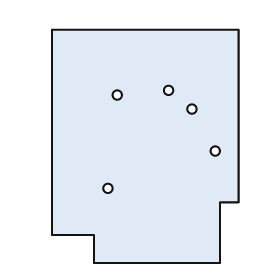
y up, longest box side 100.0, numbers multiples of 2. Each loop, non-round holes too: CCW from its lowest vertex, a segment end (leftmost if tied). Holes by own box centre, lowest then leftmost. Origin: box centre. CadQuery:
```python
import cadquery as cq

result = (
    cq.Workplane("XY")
    .moveTo(-22.0, -50.0)
    .lineTo(32.0, -50.0)
    .lineTo(32.0, -24.0)
    .lineTo(40.0, -24.0)
    .lineTo(40.0, 50.0)
    .lineTo(-40.0, 50.0)
    .lineTo(-40.0, -38.0)
    .lineTo(-22.0, -38.0)
    .close()
    .moveTo(-16.0, -18.0)
    .circle(2.0)
    .moveTo(30.0, -2.0)
    .circle(2.0)
    .moveTo(20.0, 16.0)
    .circle(2.0)
    .moveTo(-12.0, 22.0)
    .circle(2.0)
    .moveTo(10.0, 24.0)
    .circle(2.0)
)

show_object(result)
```